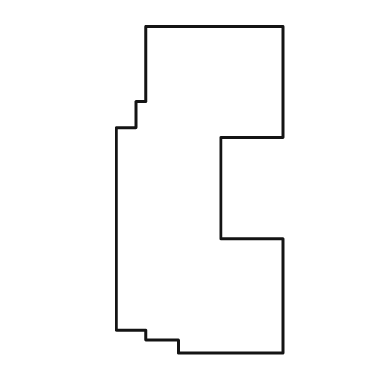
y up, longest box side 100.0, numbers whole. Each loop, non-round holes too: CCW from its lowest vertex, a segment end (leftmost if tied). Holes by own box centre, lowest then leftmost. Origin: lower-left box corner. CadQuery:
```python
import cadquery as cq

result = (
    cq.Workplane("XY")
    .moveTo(19.0, 0.0)
    .lineTo(51.0, 0.0)
    .lineTo(51.0, 35.0)
    .lineTo(32.0, 35.0)
    .lineTo(32.0, 66.0)
    .lineTo(51.0, 66.0)
    .lineTo(51.0, 100.0)
    .lineTo(9.0, 100.0)
    .lineTo(9.0, 77.0)
    .lineTo(6.0, 77.0)
    .lineTo(6.0, 69.0)
    .lineTo(0.0, 69.0)
    .lineTo(0.0, 7.0)
    .lineTo(9.0, 7.0)
    .lineTo(9.0, 4.0)
    .lineTo(19.0, 4.0)
    .close()
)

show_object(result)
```